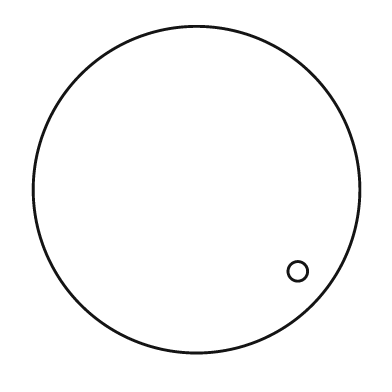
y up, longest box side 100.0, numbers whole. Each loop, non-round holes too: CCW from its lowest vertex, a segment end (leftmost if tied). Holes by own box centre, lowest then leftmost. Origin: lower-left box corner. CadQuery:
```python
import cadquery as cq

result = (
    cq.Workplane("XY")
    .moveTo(50.0, 50.0)
    .circle(50.0)
    .moveTo(81.0, 25.0)
    .circle(3.0)
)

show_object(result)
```